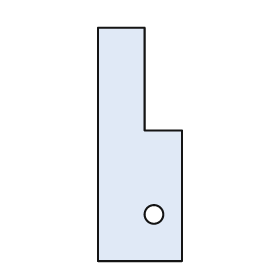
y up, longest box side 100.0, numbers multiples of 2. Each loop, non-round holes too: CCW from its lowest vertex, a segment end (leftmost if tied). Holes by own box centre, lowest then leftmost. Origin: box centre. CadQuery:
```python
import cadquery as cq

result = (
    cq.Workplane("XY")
    .moveTo(-18.0, -50.0)
    .lineTo(18.0, -50.0)
    .lineTo(18.0, 6.0)
    .lineTo(2.0, 6.0)
    .lineTo(2.0, 50.0)
    .lineTo(-18.0, 50.0)
    .close()
    .moveTo(6.0, -30.0)
    .circle(4.0)
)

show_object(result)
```